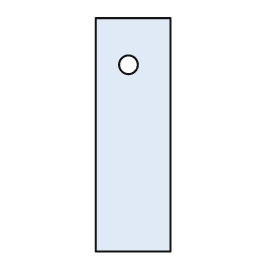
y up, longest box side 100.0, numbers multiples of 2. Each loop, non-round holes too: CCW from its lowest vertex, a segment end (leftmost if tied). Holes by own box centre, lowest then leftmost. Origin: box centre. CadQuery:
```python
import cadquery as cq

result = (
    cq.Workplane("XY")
    .moveTo(-16.0, -50.0)
    .lineTo(16.0, -50.0)
    .lineTo(16.0, 50.0)
    .lineTo(-16.0, 50.0)
    .close()
    .moveTo(-2.0, 30.0)
    .circle(4.0)
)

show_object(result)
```